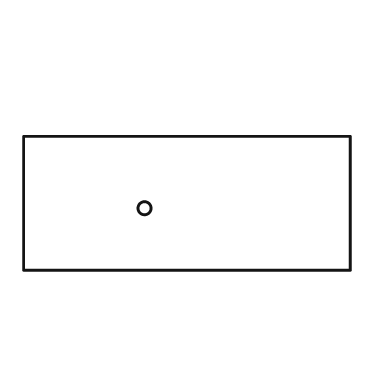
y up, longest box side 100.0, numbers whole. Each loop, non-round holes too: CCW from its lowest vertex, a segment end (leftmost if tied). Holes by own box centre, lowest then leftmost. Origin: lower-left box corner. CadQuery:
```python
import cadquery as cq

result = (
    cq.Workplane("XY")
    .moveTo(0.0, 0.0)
    .lineTo(100.0, 0.0)
    .lineTo(100.0, 41.0)
    .lineTo(0.0, 41.0)
    .close()
    .moveTo(37.0, 19.0)
    .circle(2.0)
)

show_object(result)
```